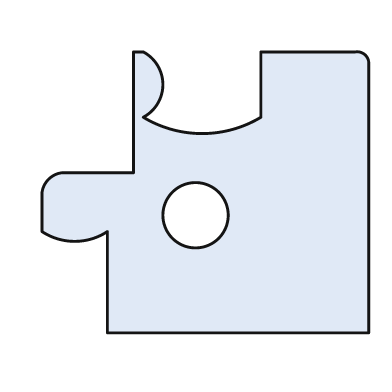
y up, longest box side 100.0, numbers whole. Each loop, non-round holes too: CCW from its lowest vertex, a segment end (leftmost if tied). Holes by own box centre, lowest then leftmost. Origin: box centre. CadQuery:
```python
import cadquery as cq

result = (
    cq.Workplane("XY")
    .moveTo(-30.0, -43.0)
    .lineTo(50.0, -43.0)
    .lineTo(50.0, 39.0)
    .threePointArc((49.0, 42.0), (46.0, 43.0))
    .lineTo(17.0, 43.0)
    .lineTo(17.0, 23.0)
    .threePointArc((-1.0, 18.0), (-19.0, 23.0))
    .threePointArc((-13.0, 33.0), (-19.0, 43.0))
    .lineTo(-22.0, 43.0)
    .lineTo(-22.0, 6.0)
    .lineTo(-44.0, 6.0)
    .threePointArc((-48.0, 4.0), (-50.0, 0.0))
    .lineTo(-50.0, -12.0)
    .threePointArc((-40.0, -15.0), (-30.0, -12.0))
    .close()
    .moveTo(-3.0, -7.0)
    .circle(10.0)
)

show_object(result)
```